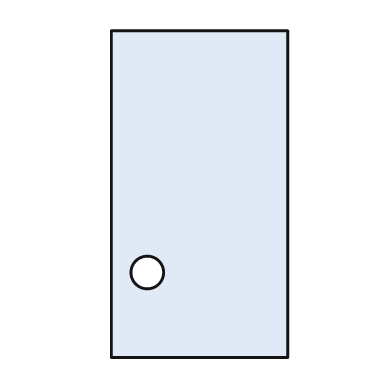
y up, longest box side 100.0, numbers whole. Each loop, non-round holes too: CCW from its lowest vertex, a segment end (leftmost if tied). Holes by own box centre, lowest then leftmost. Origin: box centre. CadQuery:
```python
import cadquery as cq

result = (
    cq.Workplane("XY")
    .moveTo(-27.0, -50.0)
    .lineTo(27.0, -50.0)
    .lineTo(27.0, 50.0)
    .lineTo(-27.0, 50.0)
    .close()
    .moveTo(-16.0, -24.0)
    .circle(5.0)
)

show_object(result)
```